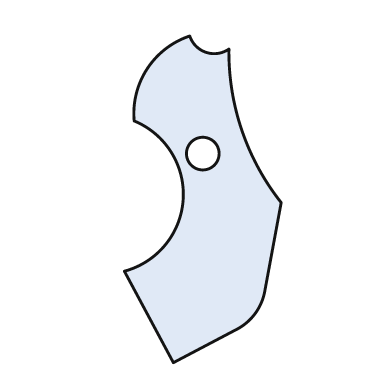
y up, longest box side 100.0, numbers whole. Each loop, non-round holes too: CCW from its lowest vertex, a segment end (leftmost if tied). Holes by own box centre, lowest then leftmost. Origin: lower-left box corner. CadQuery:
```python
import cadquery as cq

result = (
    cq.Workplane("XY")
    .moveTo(15.0, 0.0)
    .lineTo(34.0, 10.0)
    .threePointArc((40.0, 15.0), (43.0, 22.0))
    .lineTo(48.0, 49.0)
    .threePointArc((36.0, 71.0), (32.0, 96.0))
    .threePointArc((25.0, 95.0), (20.0, 100.0))
    .threePointArc((7.0, 90.0), (3.0, 74.0))
    .threePointArc((18.0, 50.0), (0.0, 28.0))
    .close()
    .moveTo(24.0, 64.0)
    .circle(5.0)
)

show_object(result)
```